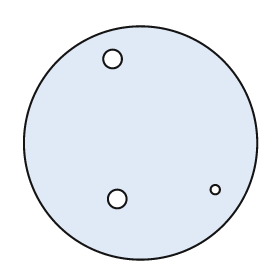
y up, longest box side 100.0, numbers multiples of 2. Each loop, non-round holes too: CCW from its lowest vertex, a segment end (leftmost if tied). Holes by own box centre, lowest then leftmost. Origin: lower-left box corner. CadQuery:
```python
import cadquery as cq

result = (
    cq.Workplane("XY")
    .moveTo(50.0, 50.0)
    .circle(50.0)
    .moveTo(40.0, 26.0)
    .circle(4.0)
    .moveTo(82.0, 30.0)
    .circle(2.0)
    .moveTo(38.0, 86.0)
    .circle(4.0)
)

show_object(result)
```